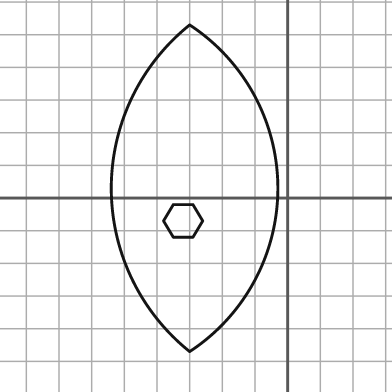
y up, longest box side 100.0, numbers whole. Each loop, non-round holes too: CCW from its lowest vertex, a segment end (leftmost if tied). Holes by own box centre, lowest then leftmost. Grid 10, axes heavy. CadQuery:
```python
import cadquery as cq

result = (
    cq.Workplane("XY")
    .moveTo(-30.0, -47.0)
    .threePointArc((-3.0, 3.0), (-30.0, 53.0))
    .threePointArc((-54.0, 3.0), (-30.0, -47.0))
    .close()
    .moveTo(-35.0, -12.0)
    .lineTo(-29.0, -12.0)
    .lineTo(-26.0, -7.0)
    .lineTo(-29.0, -2.0)
    .lineTo(-35.0, -2.0)
    .lineTo(-38.0, -7.0)
    .close()
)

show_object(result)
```